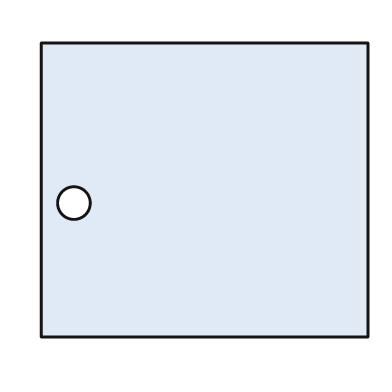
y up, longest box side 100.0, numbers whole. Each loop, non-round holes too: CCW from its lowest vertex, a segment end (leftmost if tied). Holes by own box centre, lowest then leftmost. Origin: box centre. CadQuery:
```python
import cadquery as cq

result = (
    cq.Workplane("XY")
    .moveTo(-50.0, -45.0)
    .lineTo(50.0, -45.0)
    .lineTo(50.0, 45.0)
    .lineTo(-50.0, 45.0)
    .close()
    .moveTo(-40.0, -4.0)
    .circle(5.0)
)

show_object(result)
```